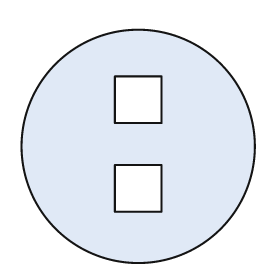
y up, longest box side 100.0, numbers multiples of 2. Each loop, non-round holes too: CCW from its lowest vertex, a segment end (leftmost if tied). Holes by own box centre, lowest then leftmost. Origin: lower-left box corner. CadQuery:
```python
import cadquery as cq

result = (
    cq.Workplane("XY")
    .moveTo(50.0, 50.0)
    .circle(50.0)
    .moveTo(40.0, 22.0)
    .lineTo(60.0, 22.0)
    .lineTo(60.0, 42.0)
    .lineTo(40.0, 42.0)
    .close()
    .moveTo(40.0, 60.0)
    .lineTo(60.0, 60.0)
    .lineTo(60.0, 80.0)
    .lineTo(40.0, 80.0)
    .close()
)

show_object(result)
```